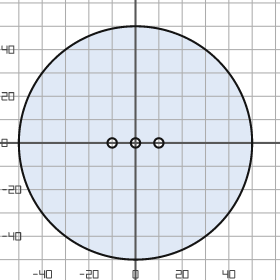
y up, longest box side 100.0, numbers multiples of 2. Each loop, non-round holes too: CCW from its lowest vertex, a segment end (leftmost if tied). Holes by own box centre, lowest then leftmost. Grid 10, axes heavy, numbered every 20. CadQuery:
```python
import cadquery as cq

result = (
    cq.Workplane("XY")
    .moveTo(0.0, 0.0)
    .circle(50.0)
    .moveTo(-10.0, 0.0)
    .circle(2.0)
    .moveTo(0.0, 0.0)
    .circle(2.0)
    .moveTo(10.0, 0.0)
    .circle(2.0)
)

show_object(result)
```